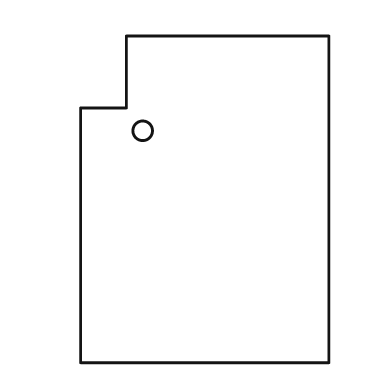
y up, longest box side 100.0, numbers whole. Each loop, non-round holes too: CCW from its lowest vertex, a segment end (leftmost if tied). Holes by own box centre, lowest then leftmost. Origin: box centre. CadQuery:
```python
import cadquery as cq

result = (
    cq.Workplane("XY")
    .moveTo(-38.0, -50.0)
    .lineTo(38.0, -50.0)
    .lineTo(38.0, 50.0)
    .lineTo(-24.0, 50.0)
    .lineTo(-24.0, 28.0)
    .lineTo(-38.0, 28.0)
    .close()
    .moveTo(-19.0, 21.0)
    .circle(3.0)
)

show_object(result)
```